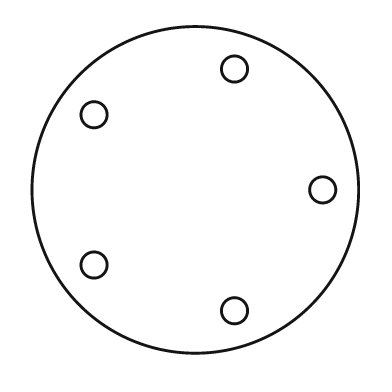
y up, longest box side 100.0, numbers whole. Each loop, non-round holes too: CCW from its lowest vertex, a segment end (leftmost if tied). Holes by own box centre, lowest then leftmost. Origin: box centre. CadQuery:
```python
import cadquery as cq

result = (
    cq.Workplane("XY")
    .moveTo(0.0, 0.0)
    .circle(50.0)
    .moveTo(12.0, -37.0)
    .circle(4.0)
    .moveTo(-31.0, -23.0)
    .circle(4.0)
    .moveTo(39.0, 0.0)
    .circle(4.0)
    .moveTo(-31.0, 23.0)
    .circle(4.0)
    .moveTo(12.0, 37.0)
    .circle(4.0)
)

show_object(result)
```